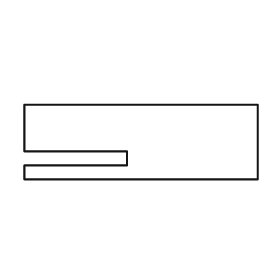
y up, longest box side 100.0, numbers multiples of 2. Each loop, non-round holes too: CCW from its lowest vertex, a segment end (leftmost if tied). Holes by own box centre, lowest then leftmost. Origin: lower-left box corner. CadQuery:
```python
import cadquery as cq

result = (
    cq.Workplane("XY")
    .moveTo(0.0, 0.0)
    .lineTo(100.0, 0.0)
    .lineTo(100.0, 32.0)
    .lineTo(0.0, 32.0)
    .lineTo(0.0, 12.0)
    .lineTo(44.0, 12.0)
    .lineTo(44.0, 6.0)
    .lineTo(0.0, 6.0)
    .close()
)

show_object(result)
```